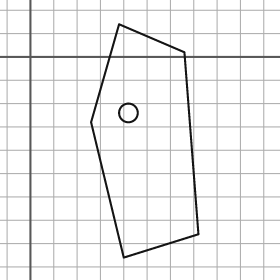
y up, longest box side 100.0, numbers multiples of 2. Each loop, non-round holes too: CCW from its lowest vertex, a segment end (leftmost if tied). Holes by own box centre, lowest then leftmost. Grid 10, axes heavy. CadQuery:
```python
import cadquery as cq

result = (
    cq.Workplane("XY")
    .moveTo(40.0, -86.0)
    .lineTo(72.0, -76.0)
    .lineTo(66.0, 2.0)
    .lineTo(38.0, 14.0)
    .lineTo(26.0, -28.0)
    .close()
    .moveTo(42.0, -24.0)
    .circle(4.0)
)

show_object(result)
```